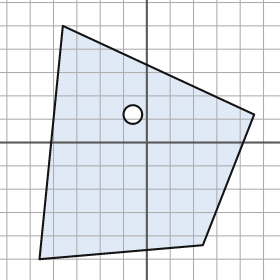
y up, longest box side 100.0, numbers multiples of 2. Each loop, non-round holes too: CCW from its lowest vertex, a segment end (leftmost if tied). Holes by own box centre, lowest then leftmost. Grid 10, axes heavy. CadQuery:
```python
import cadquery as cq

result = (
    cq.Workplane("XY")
    .moveTo(-46.0, -50.0)
    .lineTo(24.0, -44.0)
    .lineTo(46.0, 12.0)
    .lineTo(-36.0, 50.0)
    .close()
    .moveTo(-6.0, 12.0)
    .circle(4.0)
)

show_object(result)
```